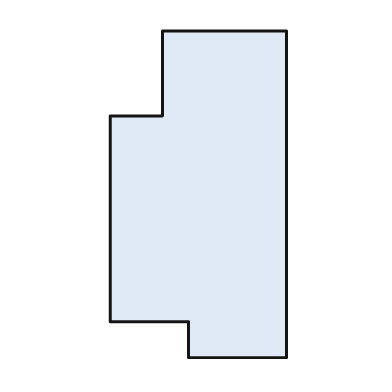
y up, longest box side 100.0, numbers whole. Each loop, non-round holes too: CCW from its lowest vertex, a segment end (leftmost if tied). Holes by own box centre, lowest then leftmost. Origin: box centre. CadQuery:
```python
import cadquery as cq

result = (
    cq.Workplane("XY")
    .moveTo(-3.0, -50.0)
    .lineTo(27.0, -50.0)
    .lineTo(27.0, 50.0)
    .lineTo(-11.0, 50.0)
    .lineTo(-11.0, 24.0)
    .lineTo(-27.0, 24.0)
    .lineTo(-27.0, -39.0)
    .lineTo(-3.0, -39.0)
    .close()
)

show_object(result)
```